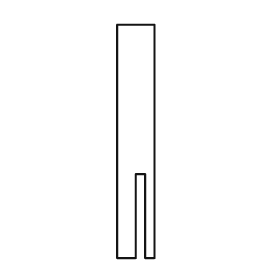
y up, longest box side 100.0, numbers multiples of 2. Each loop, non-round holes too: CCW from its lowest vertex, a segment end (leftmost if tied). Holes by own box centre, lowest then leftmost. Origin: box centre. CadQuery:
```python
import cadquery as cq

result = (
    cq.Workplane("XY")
    .moveTo(-8.0, -50.0)
    .lineTo(0.0, -50.0)
    .lineTo(0.0, -14.0)
    .lineTo(4.0, -14.0)
    .lineTo(4.0, -50.0)
    .lineTo(8.0, -50.0)
    .lineTo(8.0, 50.0)
    .lineTo(-8.0, 50.0)
    .close()
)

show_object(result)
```